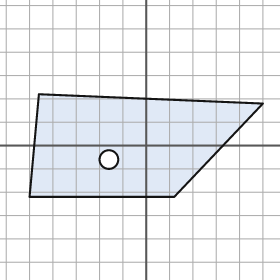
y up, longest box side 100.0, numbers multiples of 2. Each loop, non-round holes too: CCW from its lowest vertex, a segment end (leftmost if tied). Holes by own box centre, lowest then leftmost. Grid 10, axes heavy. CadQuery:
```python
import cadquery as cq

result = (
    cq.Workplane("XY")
    .moveTo(-50.0, -22.0)
    .lineTo(12.0, -22.0)
    .lineTo(50.0, 18.0)
    .lineTo(-46.0, 22.0)
    .close()
    .moveTo(-16.0, -6.0)
    .circle(4.0)
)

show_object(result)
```